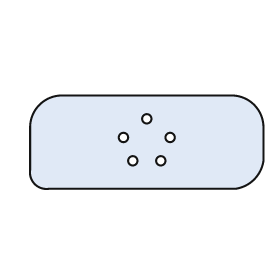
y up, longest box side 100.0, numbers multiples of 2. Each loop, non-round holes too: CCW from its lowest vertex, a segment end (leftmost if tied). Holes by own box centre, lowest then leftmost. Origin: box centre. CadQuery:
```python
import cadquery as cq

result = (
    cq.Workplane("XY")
    .moveTo(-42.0, -20.0)
    .lineTo(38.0, -20.0)
    .threePointArc((46.0, -16.0), (50.0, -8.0))
    .lineTo(50.0, 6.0)
    .threePointArc((46.0, 16.0), (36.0, 20.0))
    .lineTo(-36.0, 20.0)
    .threePointArc((-46.0, 16.0), (-50.0, 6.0))
    .lineTo(-50.0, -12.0)
    .threePointArc((-48.0, -18.0), (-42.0, -20.0))
    .close()
    .moveTo(-6.0, -8.0)
    .circle(2.0)
    .moveTo(6.0, -8.0)
    .circle(2.0)
    .moveTo(-10.0, 2.0)
    .circle(2.0)
    .moveTo(10.0, 2.0)
    .circle(2.0)
    .moveTo(0.0, 10.0)
    .circle(2.0)
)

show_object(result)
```